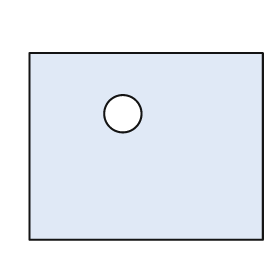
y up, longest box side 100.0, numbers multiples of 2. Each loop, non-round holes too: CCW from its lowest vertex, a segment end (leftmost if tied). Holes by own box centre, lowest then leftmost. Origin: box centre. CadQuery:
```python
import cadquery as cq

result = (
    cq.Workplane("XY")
    .moveTo(-50.0, -40.0)
    .lineTo(50.0, -40.0)
    .lineTo(50.0, 40.0)
    .lineTo(-50.0, 40.0)
    .close()
    .moveTo(-10.0, 14.0)
    .circle(8.0)
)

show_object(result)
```